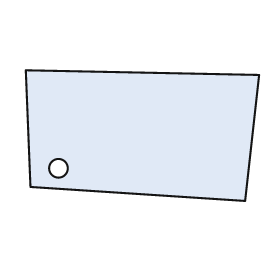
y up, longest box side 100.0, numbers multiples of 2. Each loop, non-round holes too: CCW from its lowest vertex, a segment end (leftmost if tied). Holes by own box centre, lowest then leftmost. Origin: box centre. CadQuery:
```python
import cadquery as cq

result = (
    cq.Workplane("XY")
    .moveTo(44.0, -28.0)
    .lineTo(50.0, 26.0)
    .lineTo(-50.0, 28.0)
    .lineTo(-48.0, -22.0)
    .close()
    .moveTo(-36.0, -14.0)
    .circle(4.0)
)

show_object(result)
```